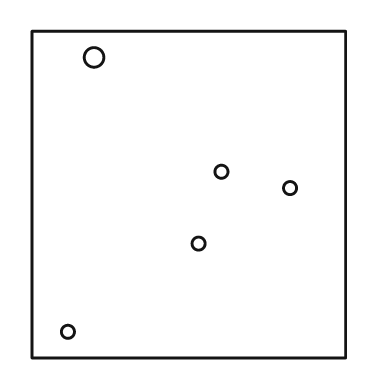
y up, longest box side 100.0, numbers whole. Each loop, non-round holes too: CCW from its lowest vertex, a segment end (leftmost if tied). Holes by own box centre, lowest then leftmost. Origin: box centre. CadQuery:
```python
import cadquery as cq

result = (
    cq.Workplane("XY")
    .moveTo(-48.0, -50.0)
    .lineTo(48.0, -50.0)
    .lineTo(48.0, 50.0)
    .lineTo(-48.0, 50.0)
    .close()
    .moveTo(-37.0, -42.0)
    .circle(2.0)
    .moveTo(3.0, -15.0)
    .circle(2.0)
    .moveTo(31.0, 2.0)
    .circle(2.0)
    .moveTo(10.0, 7.0)
    .circle(2.0)
    .moveTo(-29.0, 42.0)
    .circle(3.0)
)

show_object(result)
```